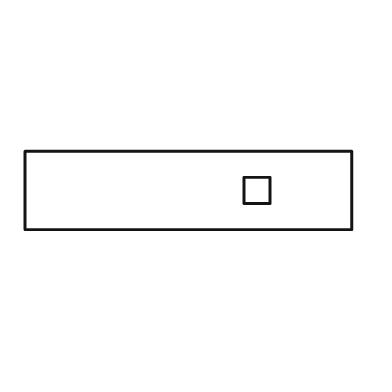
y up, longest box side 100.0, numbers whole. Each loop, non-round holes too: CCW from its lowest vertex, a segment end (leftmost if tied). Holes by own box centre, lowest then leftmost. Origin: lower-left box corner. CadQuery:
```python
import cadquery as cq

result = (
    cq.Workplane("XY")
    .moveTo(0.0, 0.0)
    .lineTo(100.0, 0.0)
    .lineTo(100.0, 24.0)
    .lineTo(0.0, 24.0)
    .close()
    .moveTo(67.0, 8.0)
    .lineTo(75.0, 8.0)
    .lineTo(75.0, 16.0)
    .lineTo(67.0, 16.0)
    .close()
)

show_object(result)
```